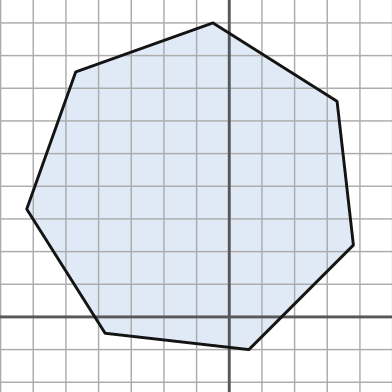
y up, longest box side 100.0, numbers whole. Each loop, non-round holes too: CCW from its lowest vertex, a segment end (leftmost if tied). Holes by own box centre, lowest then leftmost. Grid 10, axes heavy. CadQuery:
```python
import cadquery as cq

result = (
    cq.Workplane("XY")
    .moveTo(6.0, -10.0)
    .lineTo(38.0, 22.0)
    .lineTo(33.0, 66.0)
    .lineTo(-5.0, 90.0)
    .lineTo(-47.0, 75.0)
    .lineTo(-62.0, 33.0)
    .lineTo(-38.0, -5.0)
    .close()
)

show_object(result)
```